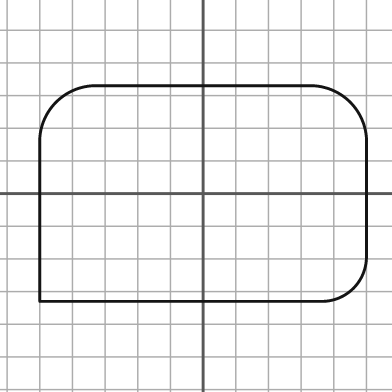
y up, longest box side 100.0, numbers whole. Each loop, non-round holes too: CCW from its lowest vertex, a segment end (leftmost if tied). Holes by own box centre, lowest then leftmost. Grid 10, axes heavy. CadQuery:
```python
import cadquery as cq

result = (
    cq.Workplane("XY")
    .moveTo(-50.0, -33.0)
    .lineTo(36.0, -33.0)
    .threePointArc((46.0, -29.0), (50.0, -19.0))
    .lineTo(50.0, 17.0)
    .threePointArc((45.0, 28.0), (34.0, 33.0))
    .lineTo(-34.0, 33.0)
    .threePointArc((-45.0, 28.0), (-50.0, 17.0))
    .close()
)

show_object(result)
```